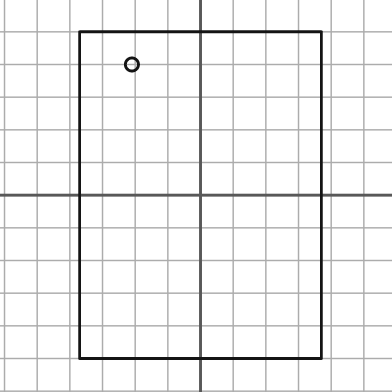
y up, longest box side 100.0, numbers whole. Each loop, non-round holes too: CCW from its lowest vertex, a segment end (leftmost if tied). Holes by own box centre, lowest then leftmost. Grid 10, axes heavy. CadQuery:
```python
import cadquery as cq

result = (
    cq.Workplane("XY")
    .moveTo(-37.0, -50.0)
    .lineTo(37.0, -50.0)
    .lineTo(37.0, 50.0)
    .lineTo(-37.0, 50.0)
    .close()
    .moveTo(-21.0, 40.0)
    .circle(2.0)
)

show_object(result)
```